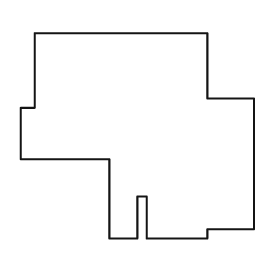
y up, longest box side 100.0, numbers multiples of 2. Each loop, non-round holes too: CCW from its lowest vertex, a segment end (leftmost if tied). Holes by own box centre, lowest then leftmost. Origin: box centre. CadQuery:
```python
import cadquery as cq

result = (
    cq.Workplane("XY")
    .moveTo(-12.0, -44.0)
    .lineTo(0.0, -44.0)
    .lineTo(0.0, -26.0)
    .lineTo(4.0, -26.0)
    .lineTo(4.0, -44.0)
    .lineTo(30.0, -44.0)
    .lineTo(30.0, -40.0)
    .lineTo(50.0, -40.0)
    .lineTo(50.0, 16.0)
    .lineTo(30.0, 16.0)
    .lineTo(30.0, 44.0)
    .lineTo(-44.0, 44.0)
    .lineTo(-44.0, 12.0)
    .lineTo(-50.0, 12.0)
    .lineTo(-50.0, -10.0)
    .lineTo(-12.0, -10.0)
    .close()
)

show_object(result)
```